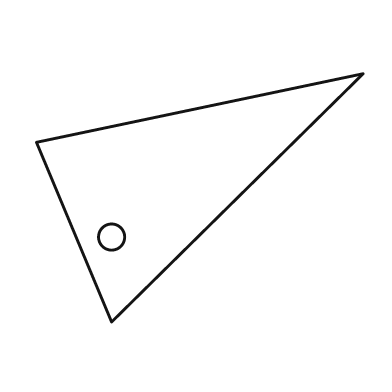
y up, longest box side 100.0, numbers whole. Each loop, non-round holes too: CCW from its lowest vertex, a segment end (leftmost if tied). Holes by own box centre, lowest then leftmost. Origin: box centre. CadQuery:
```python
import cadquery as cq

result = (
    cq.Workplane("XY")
    .moveTo(-27.0, -38.0)
    .lineTo(50.0, 38.0)
    .lineTo(-50.0, 17.0)
    .close()
    .moveTo(-27.0, -12.0)
    .circle(4.0)
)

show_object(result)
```